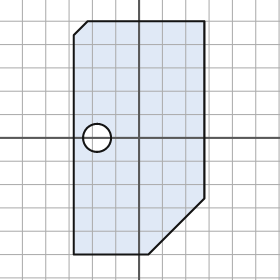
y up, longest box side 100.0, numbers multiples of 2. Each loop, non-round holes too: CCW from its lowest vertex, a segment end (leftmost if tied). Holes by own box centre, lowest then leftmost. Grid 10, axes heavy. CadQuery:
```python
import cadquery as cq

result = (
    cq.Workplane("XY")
    .moveTo(-28.0, -50.0)
    .lineTo(4.0, -50.0)
    .lineTo(28.0, -26.0)
    .lineTo(28.0, 50.0)
    .lineTo(-22.0, 50.0)
    .lineTo(-28.0, 44.0)
    .close()
    .moveTo(-18.0, 0.0)
    .circle(6.0)
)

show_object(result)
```